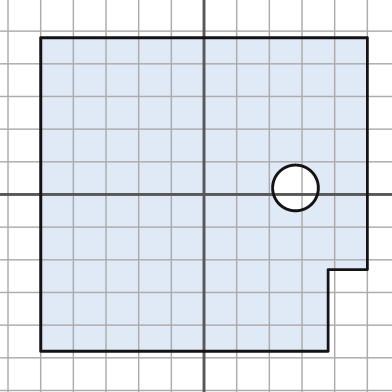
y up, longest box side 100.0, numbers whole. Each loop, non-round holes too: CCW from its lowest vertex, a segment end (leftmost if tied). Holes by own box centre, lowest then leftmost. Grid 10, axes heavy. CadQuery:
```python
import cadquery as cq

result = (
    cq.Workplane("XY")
    .moveTo(-50.0, -48.0)
    .lineTo(38.0, -48.0)
    .lineTo(38.0, -23.0)
    .lineTo(50.0, -23.0)
    .lineTo(50.0, 48.0)
    .lineTo(-50.0, 48.0)
    .close()
    .moveTo(28.0, 2.0)
    .circle(7.0)
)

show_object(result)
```